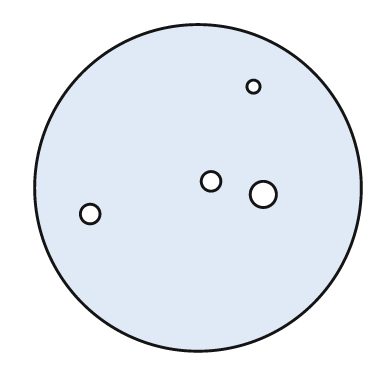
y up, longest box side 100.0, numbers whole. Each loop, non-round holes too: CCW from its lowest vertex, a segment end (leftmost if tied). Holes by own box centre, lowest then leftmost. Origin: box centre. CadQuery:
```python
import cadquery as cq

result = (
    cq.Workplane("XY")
    .moveTo(0.0, 0.0)
    .circle(50.0)
    .moveTo(-33.0, -8.0)
    .circle(3.0)
    .moveTo(20.0, -2.0)
    .circle(4.0)
    .moveTo(4.0, 2.0)
    .circle(3.0)
    .moveTo(17.0, 31.0)
    .circle(2.0)
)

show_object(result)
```